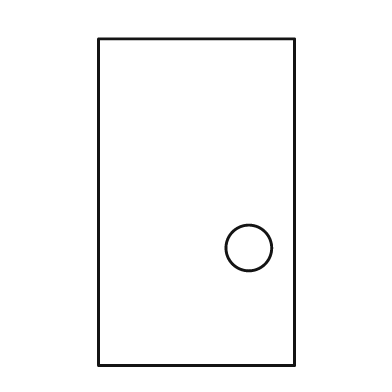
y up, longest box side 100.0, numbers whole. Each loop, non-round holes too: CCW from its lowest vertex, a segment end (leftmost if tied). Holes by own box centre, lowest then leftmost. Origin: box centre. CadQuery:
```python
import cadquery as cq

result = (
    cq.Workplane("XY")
    .moveTo(-30.0, -50.0)
    .lineTo(30.0, -50.0)
    .lineTo(30.0, 50.0)
    .lineTo(-30.0, 50.0)
    .close()
    .moveTo(16.0, -14.0)
    .circle(7.0)
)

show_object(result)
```